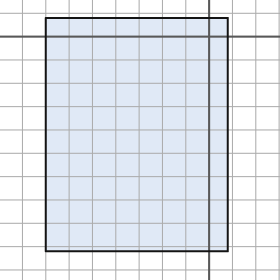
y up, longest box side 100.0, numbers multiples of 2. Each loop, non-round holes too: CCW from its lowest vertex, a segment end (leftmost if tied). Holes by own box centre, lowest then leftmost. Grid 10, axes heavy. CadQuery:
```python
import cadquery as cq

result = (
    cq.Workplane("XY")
    .moveTo(-70.0, -92.0)
    .lineTo(8.0, -92.0)
    .lineTo(8.0, 8.0)
    .lineTo(-70.0, 8.0)
    .close()
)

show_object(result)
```